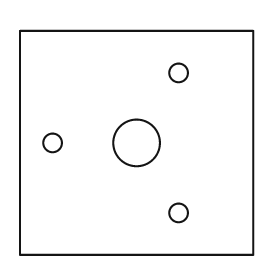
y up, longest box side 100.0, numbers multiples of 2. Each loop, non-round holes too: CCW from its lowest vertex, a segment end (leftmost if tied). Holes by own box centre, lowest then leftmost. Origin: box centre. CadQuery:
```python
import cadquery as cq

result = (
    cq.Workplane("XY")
    .moveTo(-50.0, -48.0)
    .lineTo(50.0, -48.0)
    .lineTo(50.0, 48.0)
    .lineTo(-50.0, 48.0)
    .close()
    .moveTo(18.0, -30.0)
    .circle(4.0)
    .moveTo(-36.0, 0.0)
    .circle(4.0)
    .moveTo(0.0, 0.0)
    .circle(10.0)
    .moveTo(18.0, 30.0)
    .circle(4.0)
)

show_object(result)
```